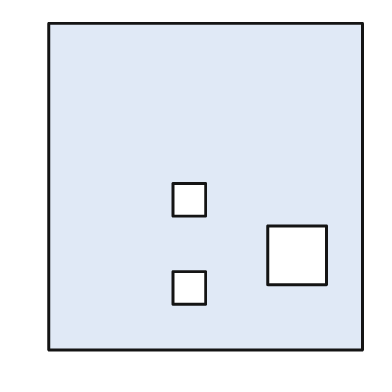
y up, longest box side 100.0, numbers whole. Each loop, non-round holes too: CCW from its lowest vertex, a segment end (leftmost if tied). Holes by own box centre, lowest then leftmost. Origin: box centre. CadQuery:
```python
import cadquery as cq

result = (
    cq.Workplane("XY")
    .moveTo(-48.0, -50.0)
    .lineTo(48.0, -50.0)
    .lineTo(48.0, 50.0)
    .lineTo(-48.0, 50.0)
    .close()
    .moveTo(-10.0, -36.0)
    .lineTo(0.0, -36.0)
    .lineTo(0.0, -26.0)
    .lineTo(-10.0, -26.0)
    .close()
    .moveTo(19.0, -30.0)
    .lineTo(37.0, -30.0)
    .lineTo(37.0, -12.0)
    .lineTo(19.0, -12.0)
    .close()
    .moveTo(-10.0, -9.0)
    .lineTo(0.0, -9.0)
    .lineTo(0.0, 1.0)
    .lineTo(-10.0, 1.0)
    .close()
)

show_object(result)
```